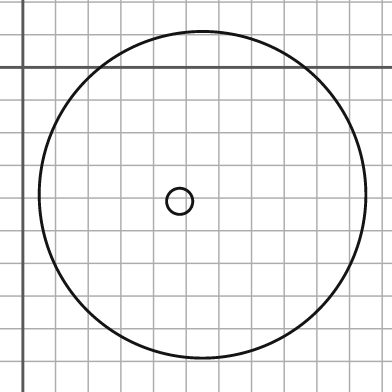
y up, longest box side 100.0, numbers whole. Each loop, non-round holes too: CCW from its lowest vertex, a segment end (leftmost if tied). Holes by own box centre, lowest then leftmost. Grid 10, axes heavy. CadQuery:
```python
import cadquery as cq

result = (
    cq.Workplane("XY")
    .moveTo(55.0, -39.0)
    .circle(50.0)
    .moveTo(48.0, -41.0)
    .circle(4.0)
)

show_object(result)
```